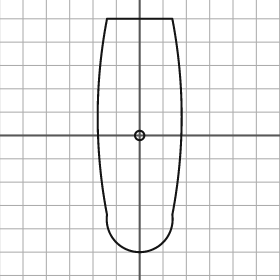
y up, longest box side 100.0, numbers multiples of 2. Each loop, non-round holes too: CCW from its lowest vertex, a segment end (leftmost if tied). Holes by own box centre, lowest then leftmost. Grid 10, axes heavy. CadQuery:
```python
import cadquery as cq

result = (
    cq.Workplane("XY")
    .moveTo(-14.0, -34.0)
    .threePointArc((0.0, -50.0), (14.0, -34.0))
    .threePointArc((18.0, 8.0), (14.0, 50.0))
    .lineTo(-14.0, 50.0)
    .threePointArc((-18.0, 8.0), (-14.0, -34.0))
    .close()
    .moveTo(0.0, 0.0)
    .circle(2.0)
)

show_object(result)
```